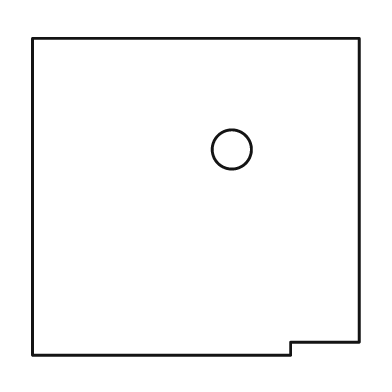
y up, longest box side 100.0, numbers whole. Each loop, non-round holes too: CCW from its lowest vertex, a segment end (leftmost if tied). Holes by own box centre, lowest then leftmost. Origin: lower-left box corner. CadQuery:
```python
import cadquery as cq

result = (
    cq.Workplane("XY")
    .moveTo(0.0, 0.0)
    .lineTo(79.0, 0.0)
    .lineTo(79.0, 4.0)
    .lineTo(100.0, 4.0)
    .lineTo(100.0, 97.0)
    .lineTo(0.0, 97.0)
    .close()
    .moveTo(61.0, 63.0)
    .circle(6.0)
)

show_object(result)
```